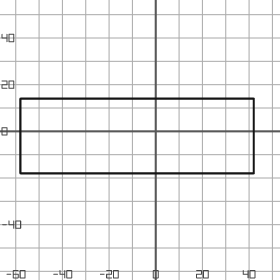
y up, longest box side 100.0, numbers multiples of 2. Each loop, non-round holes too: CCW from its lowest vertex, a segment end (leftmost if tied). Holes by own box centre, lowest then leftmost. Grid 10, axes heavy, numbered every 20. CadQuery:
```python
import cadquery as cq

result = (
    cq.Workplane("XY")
    .moveTo(-58.0, -18.0)
    .lineTo(42.0, -18.0)
    .lineTo(42.0, 14.0)
    .lineTo(-58.0, 14.0)
    .close()
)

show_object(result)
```